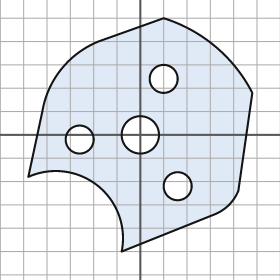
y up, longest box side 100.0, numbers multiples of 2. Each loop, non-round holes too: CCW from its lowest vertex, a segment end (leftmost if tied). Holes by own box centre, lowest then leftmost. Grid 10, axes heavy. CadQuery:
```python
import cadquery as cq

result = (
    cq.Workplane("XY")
    .moveTo(-8.0, -50.0)
    .lineTo(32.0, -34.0)
    .threePointArc((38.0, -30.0), (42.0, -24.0))
    .lineTo(48.0, 18.0)
    .threePointArc((32.0, 38.0), (10.0, 50.0))
    .lineTo(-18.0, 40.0)
    .threePointArc((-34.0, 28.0), (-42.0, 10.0))
    .lineTo(-48.0, -18.0)
    .threePointArc((-18.0, -22.0), (-8.0, -50.0))
    .close()
    .moveTo(16.0, -22.0)
    .circle(6.0)
    .moveTo(-26.0, -2.0)
    .circle(6.0)
    .moveTo(0.0, 0.0)
    .circle(8.0)
    .moveTo(10.0, 24.0)
    .circle(6.0)
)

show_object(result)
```